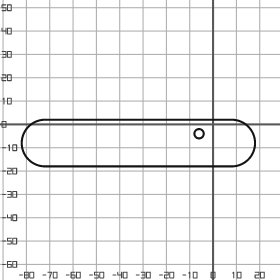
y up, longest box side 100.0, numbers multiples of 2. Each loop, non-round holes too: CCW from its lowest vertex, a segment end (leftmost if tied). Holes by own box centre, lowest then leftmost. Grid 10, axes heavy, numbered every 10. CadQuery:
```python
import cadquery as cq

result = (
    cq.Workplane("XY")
    .moveTo(-72.0, -18.0)
    .lineTo(8.0, -18.0)
    .threePointArc((18.0, -8.0), (8.0, 2.0))
    .lineTo(-72.0, 2.0)
    .threePointArc((-82.0, -8.0), (-72.0, -18.0))
    .close()
    .moveTo(-6.0, -4.0)
    .circle(2.0)
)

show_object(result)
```